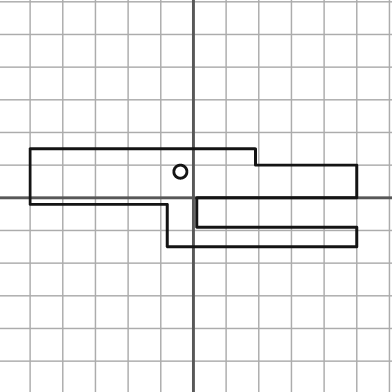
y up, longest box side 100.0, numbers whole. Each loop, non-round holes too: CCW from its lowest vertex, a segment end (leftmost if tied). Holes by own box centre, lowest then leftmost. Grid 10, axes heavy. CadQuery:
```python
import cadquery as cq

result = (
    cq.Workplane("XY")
    .moveTo(-8.0, -15.0)
    .lineTo(50.0, -15.0)
    .lineTo(50.0, -9.0)
    .lineTo(1.0, -9.0)
    .lineTo(1.0, 0.0)
    .lineTo(50.0, 0.0)
    .lineTo(50.0, 10.0)
    .lineTo(19.0, 10.0)
    .lineTo(19.0, 15.0)
    .lineTo(-50.0, 15.0)
    .lineTo(-50.0, -2.0)
    .lineTo(-8.0, -2.0)
    .close()
    .moveTo(-4.0, 8.0)
    .circle(2.0)
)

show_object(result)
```